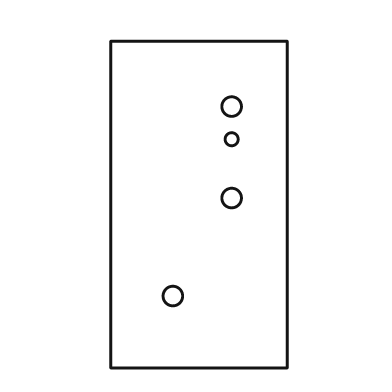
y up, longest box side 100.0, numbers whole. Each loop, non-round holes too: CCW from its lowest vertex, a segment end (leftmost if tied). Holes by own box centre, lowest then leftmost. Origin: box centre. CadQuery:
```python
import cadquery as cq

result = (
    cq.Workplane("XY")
    .moveTo(-27.0, -50.0)
    .lineTo(27.0, -50.0)
    .lineTo(27.0, 50.0)
    .lineTo(-27.0, 50.0)
    .close()
    .moveTo(-8.0, -28.0)
    .circle(3.0)
    .moveTo(10.0, 2.0)
    .circle(3.0)
    .moveTo(10.0, 20.0)
    .circle(2.0)
    .moveTo(10.0, 30.0)
    .circle(3.0)
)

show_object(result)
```